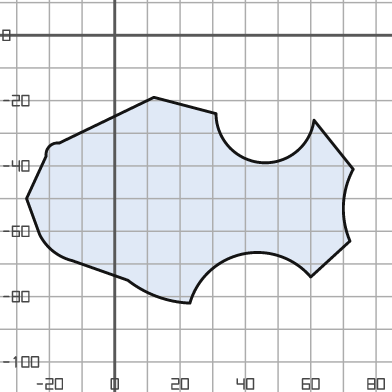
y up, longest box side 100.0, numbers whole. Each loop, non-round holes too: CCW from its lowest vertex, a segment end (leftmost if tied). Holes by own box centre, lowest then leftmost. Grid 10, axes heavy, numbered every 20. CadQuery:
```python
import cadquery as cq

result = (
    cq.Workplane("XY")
    .moveTo(23.0, -82.0)
    .threePointArc((39.0, -67.0), (60.0, -74.0))
    .lineTo(72.0, -63.0)
    .threePointArc((70.0, -52.0), (73.0, -41.0))
    .lineTo(61.0, -26.0)
    .threePointArc((45.0, -39.0), (31.0, -24.0))
    .lineTo(12.0, -19.0)
    .lineTo(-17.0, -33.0)
    .threePointArc((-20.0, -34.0), (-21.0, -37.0))
    .lineTo(-27.0, -50.0)
    .lineTo(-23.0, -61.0)
    .threePointArc((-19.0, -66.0), (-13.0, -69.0))
    .lineTo(4.0, -75.0)
    .threePointArc((13.0, -80.0), (23.0, -82.0))
    .close()
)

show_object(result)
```